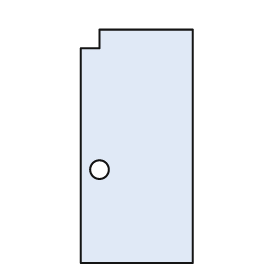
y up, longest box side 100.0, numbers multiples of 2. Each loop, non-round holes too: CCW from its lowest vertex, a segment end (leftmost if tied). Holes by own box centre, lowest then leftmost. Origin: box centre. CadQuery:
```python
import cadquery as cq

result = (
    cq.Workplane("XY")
    .moveTo(-24.0, -50.0)
    .lineTo(24.0, -50.0)
    .lineTo(24.0, 50.0)
    .lineTo(-16.0, 50.0)
    .lineTo(-16.0, 42.0)
    .lineTo(-24.0, 42.0)
    .close()
    .moveTo(-16.0, -10.0)
    .circle(4.0)
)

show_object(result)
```